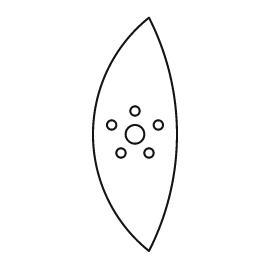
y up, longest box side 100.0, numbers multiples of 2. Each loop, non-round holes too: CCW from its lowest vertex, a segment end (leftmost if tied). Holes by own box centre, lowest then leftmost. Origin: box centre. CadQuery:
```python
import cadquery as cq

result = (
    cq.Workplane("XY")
    .moveTo(6.0, -50.0)
    .threePointArc((18.0, 0.0), (6.0, 50.0))
    .threePointArc((-18.0, 0.0), (6.0, -50.0))
    .close()
    .moveTo(-6.0, -8.0)
    .circle(2.0)
    .moveTo(6.0, -8.0)
    .circle(2.0)
    .moveTo(0.0, 0.0)
    .circle(4.0)
    .moveTo(-10.0, 4.0)
    .circle(2.0)
    .moveTo(10.0, 4.0)
    .circle(2.0)
    .moveTo(0.0, 10.0)
    .circle(2.0)
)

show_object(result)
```